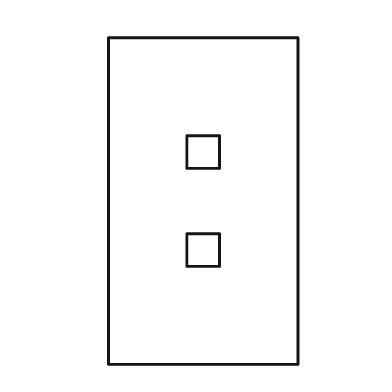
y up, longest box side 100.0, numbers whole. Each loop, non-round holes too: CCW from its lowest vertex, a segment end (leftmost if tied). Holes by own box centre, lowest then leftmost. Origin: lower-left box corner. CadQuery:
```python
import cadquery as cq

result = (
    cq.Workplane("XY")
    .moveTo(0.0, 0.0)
    .lineTo(58.0, 0.0)
    .lineTo(58.0, 100.0)
    .lineTo(0.0, 100.0)
    .close()
    .moveTo(24.0, 30.0)
    .lineTo(34.0, 30.0)
    .lineTo(34.0, 40.0)
    .lineTo(24.0, 40.0)
    .close()
    .moveTo(24.0, 60.0)
    .lineTo(34.0, 60.0)
    .lineTo(34.0, 70.0)
    .lineTo(24.0, 70.0)
    .close()
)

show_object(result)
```